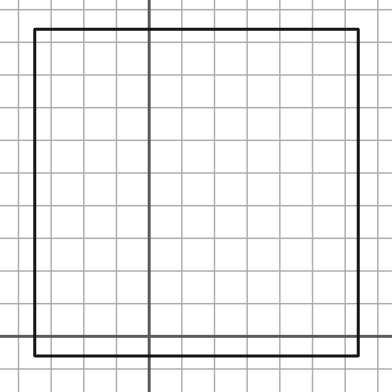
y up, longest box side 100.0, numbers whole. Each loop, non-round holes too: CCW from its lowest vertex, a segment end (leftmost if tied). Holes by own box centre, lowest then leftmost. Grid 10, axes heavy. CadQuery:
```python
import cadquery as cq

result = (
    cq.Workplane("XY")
    .moveTo(-35.0, -6.0)
    .lineTo(64.0, -6.0)
    .lineTo(64.0, 94.0)
    .lineTo(-35.0, 94.0)
    .close()
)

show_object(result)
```